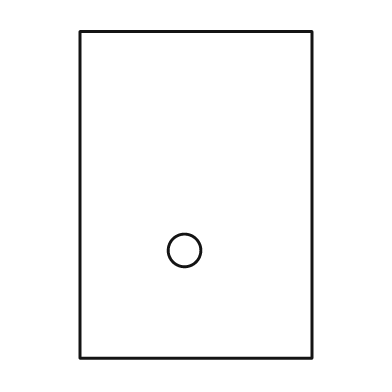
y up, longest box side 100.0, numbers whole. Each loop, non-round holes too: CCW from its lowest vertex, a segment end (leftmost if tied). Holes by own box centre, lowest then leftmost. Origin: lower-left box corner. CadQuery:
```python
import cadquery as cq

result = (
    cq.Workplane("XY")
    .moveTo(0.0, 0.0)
    .lineTo(71.0, 0.0)
    .lineTo(71.0, 100.0)
    .lineTo(0.0, 100.0)
    .close()
    .moveTo(32.0, 33.0)
    .circle(5.0)
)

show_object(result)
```